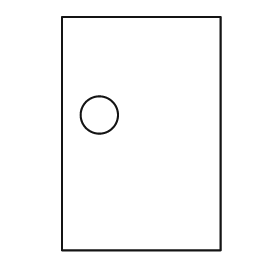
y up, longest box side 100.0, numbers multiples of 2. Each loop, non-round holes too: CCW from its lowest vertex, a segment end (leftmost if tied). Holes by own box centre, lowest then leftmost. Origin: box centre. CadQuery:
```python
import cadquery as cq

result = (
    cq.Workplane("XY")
    .moveTo(-34.0, -50.0)
    .lineTo(34.0, -50.0)
    .lineTo(34.0, 50.0)
    .lineTo(-34.0, 50.0)
    .close()
    .moveTo(-18.0, 8.0)
    .circle(8.0)
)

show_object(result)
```